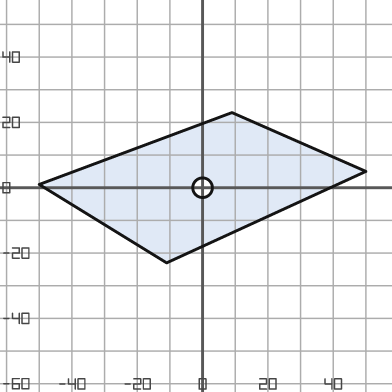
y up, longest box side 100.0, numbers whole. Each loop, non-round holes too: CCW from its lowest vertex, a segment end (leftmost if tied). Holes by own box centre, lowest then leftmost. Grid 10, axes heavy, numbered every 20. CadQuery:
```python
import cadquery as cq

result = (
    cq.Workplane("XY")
    .moveTo(-11.0, -23.0)
    .lineTo(50.0, 5.0)
    .lineTo(9.0, 23.0)
    .lineTo(-50.0, 1.0)
    .close()
    .moveTo(0.0, 0.0)
    .circle(3.0)
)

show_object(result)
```